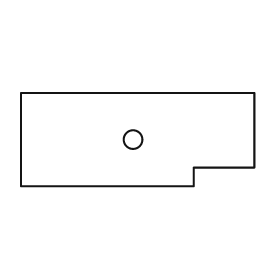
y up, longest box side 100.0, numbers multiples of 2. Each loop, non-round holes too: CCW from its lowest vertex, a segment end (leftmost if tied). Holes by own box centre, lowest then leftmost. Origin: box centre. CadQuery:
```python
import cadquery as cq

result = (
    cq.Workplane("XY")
    .moveTo(-50.0, -20.0)
    .lineTo(24.0, -20.0)
    .lineTo(24.0, -12.0)
    .lineTo(50.0, -12.0)
    .lineTo(50.0, 20.0)
    .lineTo(-50.0, 20.0)
    .close()
    .moveTo(-2.0, 0.0)
    .circle(4.0)
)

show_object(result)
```